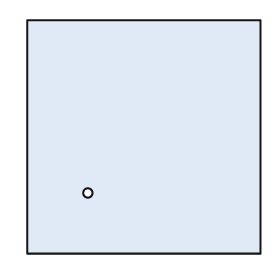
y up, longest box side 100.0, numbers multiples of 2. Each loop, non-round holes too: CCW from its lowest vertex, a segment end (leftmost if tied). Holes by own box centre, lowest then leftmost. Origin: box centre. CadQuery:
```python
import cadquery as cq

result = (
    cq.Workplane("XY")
    .moveTo(-50.0, -50.0)
    .lineTo(50.0, -50.0)
    .lineTo(50.0, 50.0)
    .lineTo(-50.0, 50.0)
    .close()
    .moveTo(-24.0, -24.0)
    .circle(2.0)
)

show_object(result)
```